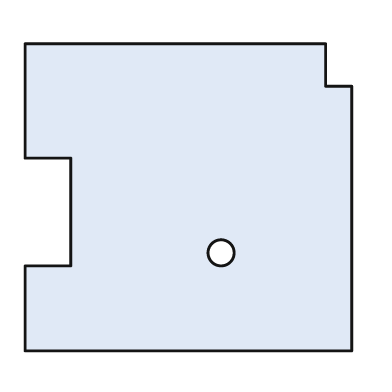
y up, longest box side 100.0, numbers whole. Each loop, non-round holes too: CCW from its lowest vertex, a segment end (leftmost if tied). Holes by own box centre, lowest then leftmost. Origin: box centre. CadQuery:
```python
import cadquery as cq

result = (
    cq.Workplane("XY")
    .moveTo(-50.0, -47.0)
    .lineTo(50.0, -47.0)
    .lineTo(50.0, 34.0)
    .lineTo(42.0, 34.0)
    .lineTo(42.0, 47.0)
    .lineTo(-50.0, 47.0)
    .lineTo(-50.0, 12.0)
    .lineTo(-36.0, 12.0)
    .lineTo(-36.0, -21.0)
    .lineTo(-50.0, -21.0)
    .close()
    .moveTo(10.0, -17.0)
    .circle(4.0)
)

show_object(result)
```